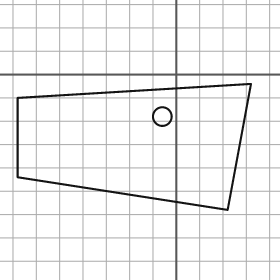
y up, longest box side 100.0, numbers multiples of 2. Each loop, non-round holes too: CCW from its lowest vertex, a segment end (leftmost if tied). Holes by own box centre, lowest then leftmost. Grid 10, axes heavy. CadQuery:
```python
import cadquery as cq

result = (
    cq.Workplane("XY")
    .moveTo(22.0, -58.0)
    .lineTo(32.0, -4.0)
    .lineTo(-68.0, -10.0)
    .lineTo(-68.0, -44.0)
    .close()
    .moveTo(-6.0, -18.0)
    .circle(4.0)
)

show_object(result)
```